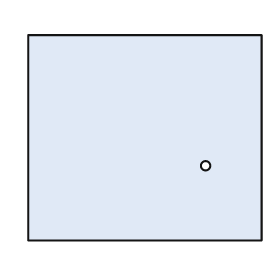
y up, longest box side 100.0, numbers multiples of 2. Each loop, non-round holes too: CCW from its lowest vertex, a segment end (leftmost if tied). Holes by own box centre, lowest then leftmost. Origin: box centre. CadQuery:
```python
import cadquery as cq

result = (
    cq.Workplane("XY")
    .moveTo(-50.0, -44.0)
    .lineTo(50.0, -44.0)
    .lineTo(50.0, 44.0)
    .lineTo(-50.0, 44.0)
    .close()
    .moveTo(26.0, -12.0)
    .circle(2.0)
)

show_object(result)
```